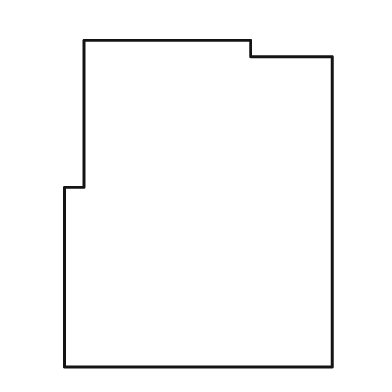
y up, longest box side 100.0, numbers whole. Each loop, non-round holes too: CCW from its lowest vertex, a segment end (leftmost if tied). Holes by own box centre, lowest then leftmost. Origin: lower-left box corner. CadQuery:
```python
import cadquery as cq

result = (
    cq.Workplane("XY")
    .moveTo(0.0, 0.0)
    .lineTo(82.0, 0.0)
    .lineTo(82.0, 95.0)
    .lineTo(57.0, 95.0)
    .lineTo(57.0, 100.0)
    .lineTo(6.0, 100.0)
    .lineTo(6.0, 55.0)
    .lineTo(0.0, 55.0)
    .close()
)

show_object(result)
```